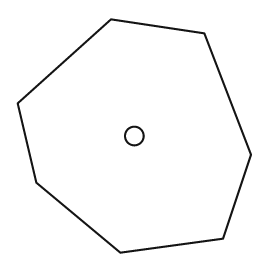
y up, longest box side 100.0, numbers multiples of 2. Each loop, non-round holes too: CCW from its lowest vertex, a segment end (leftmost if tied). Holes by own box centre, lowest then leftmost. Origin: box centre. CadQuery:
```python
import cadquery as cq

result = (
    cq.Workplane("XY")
    .moveTo(-6.0, -50.0)
    .lineTo(38.0, -44.0)
    .lineTo(50.0, -8.0)
    .lineTo(30.0, 44.0)
    .lineTo(-10.0, 50.0)
    .lineTo(-50.0, 14.0)
    .lineTo(-42.0, -20.0)
    .close()
    .moveTo(0.0, 0.0)
    .circle(4.0)
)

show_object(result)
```